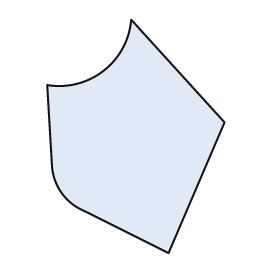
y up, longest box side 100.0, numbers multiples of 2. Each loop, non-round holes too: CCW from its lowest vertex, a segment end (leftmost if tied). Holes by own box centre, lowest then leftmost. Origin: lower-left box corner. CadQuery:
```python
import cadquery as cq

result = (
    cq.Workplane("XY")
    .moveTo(52.0, 0.0)
    .lineTo(76.0, 56.0)
    .lineTo(36.0, 100.0)
    .threePointArc((24.0, 78.0), (0.0, 72.0))
    .lineTo(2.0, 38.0)
    .threePointArc((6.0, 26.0), (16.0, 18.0))
    .close()
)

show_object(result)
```